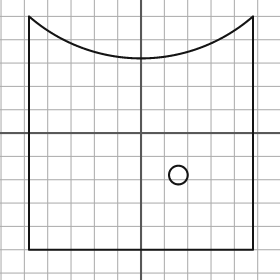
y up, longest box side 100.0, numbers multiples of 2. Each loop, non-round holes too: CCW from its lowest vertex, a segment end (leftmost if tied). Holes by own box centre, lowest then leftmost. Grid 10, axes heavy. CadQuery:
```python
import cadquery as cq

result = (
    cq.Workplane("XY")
    .moveTo(-48.0, -50.0)
    .lineTo(48.0, -50.0)
    .lineTo(48.0, 50.0)
    .threePointArc((0.0, 32.0), (-48.0, 50.0))
    .close()
    .moveTo(16.0, -18.0)
    .circle(4.0)
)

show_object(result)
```